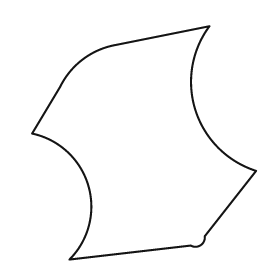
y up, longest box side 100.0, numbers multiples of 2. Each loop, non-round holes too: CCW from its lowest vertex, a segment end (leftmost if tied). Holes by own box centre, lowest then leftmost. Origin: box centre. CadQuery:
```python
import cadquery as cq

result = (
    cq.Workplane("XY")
    .moveTo(-32.0, -50.0)
    .lineTo(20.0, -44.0)
    .threePointArc((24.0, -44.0), (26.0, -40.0))
    .lineTo(48.0, -12.0)
    .threePointArc((22.0, 14.0), (28.0, 50.0))
    .lineTo(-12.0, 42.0)
    .threePointArc((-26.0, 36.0), (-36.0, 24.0))
    .lineTo(-48.0, 4.0)
    .threePointArc((-24.0, -18.0), (-32.0, -50.0))
    .close()
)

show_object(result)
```